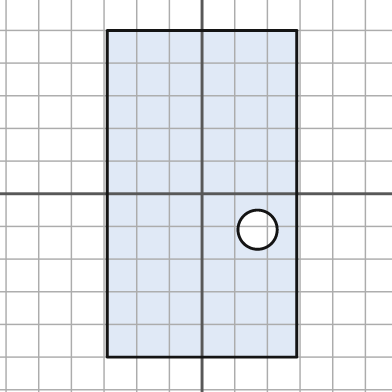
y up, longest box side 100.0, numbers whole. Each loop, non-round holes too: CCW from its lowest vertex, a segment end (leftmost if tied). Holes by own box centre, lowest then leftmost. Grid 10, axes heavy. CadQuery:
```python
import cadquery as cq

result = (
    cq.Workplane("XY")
    .moveTo(-29.0, -50.0)
    .lineTo(29.0, -50.0)
    .lineTo(29.0, 50.0)
    .lineTo(-29.0, 50.0)
    .close()
    .moveTo(17.0, -11.0)
    .circle(6.0)
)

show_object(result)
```